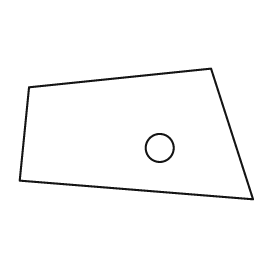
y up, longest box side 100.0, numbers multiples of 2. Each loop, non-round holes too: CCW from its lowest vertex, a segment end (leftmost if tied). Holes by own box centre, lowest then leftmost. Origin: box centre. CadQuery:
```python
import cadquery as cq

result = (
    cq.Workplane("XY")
    .moveTo(50.0, -28.0)
    .lineTo(32.0, 28.0)
    .lineTo(-46.0, 20.0)
    .lineTo(-50.0, -20.0)
    .close()
    .moveTo(10.0, -6.0)
    .circle(6.0)
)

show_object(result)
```